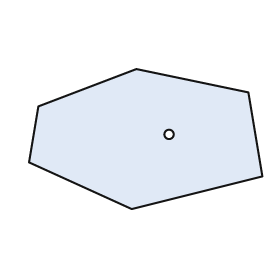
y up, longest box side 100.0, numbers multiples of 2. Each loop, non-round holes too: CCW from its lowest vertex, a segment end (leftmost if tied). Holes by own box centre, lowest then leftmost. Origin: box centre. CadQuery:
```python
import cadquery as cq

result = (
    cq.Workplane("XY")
    .moveTo(-6.0, -30.0)
    .lineTo(50.0, -16.0)
    .lineTo(44.0, 20.0)
    .lineTo(-4.0, 30.0)
    .lineTo(-46.0, 14.0)
    .lineTo(-50.0, -10.0)
    .close()
    .moveTo(10.0, 2.0)
    .circle(2.0)
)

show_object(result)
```